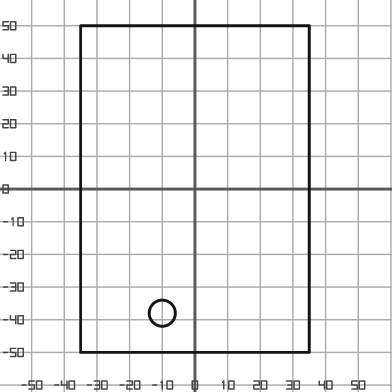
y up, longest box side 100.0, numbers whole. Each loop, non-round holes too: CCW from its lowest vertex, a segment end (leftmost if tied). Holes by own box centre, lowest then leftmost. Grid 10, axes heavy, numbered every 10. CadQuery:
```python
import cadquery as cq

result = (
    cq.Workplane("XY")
    .moveTo(-35.0, -50.0)
    .lineTo(35.0, -50.0)
    .lineTo(35.0, 50.0)
    .lineTo(-35.0, 50.0)
    .close()
    .moveTo(-10.0, -38.0)
    .circle(4.0)
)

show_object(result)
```